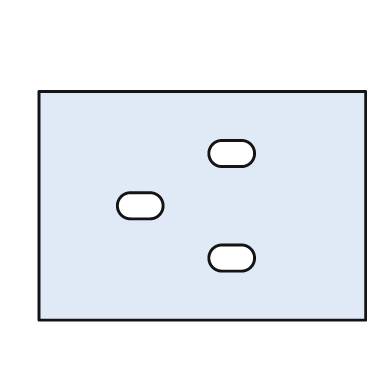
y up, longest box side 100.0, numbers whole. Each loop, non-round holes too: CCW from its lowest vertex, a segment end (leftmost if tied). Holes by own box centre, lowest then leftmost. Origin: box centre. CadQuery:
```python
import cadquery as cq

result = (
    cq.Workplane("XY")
    .moveTo(-50.0, -35.0)
    .lineTo(50.0, -35.0)
    .lineTo(50.0, 35.0)
    .lineTo(-50.0, 35.0)
    .close()
    .moveTo(6.0, -20.0)
    .lineTo(12.0, -20.0)
    .threePointArc((16.0, -16.0), (12.0, -12.0))
    .lineTo(6.0, -12.0)
    .threePointArc((2.0, -16.0), (6.0, -20.0))
    .close()
    .moveTo(-22.0, -4.0)
    .lineTo(-16.0, -4.0)
    .threePointArc((-12.0, 0.0), (-16.0, 4.0))
    .lineTo(-22.0, 4.0)
    .threePointArc((-26.0, 0.0), (-22.0, -4.0))
    .close()
    .moveTo(6.0, 12.0)
    .lineTo(12.0, 12.0)
    .threePointArc((16.0, 16.0), (12.0, 20.0))
    .lineTo(6.0, 20.0)
    .threePointArc((2.0, 16.0), (6.0, 12.0))
    .close()
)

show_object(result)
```